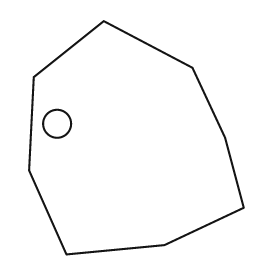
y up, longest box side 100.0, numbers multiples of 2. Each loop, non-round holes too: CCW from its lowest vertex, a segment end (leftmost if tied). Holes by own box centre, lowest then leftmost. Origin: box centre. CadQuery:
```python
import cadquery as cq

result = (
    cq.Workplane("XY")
    .moveTo(-30.0, -50.0)
    .lineTo(12.0, -46.0)
    .lineTo(46.0, -30.0)
    .lineTo(38.0, 0.0)
    .lineTo(24.0, 30.0)
    .lineTo(-14.0, 50.0)
    .lineTo(-44.0, 26.0)
    .lineTo(-46.0, -14.0)
    .close()
    .moveTo(-34.0, 6.0)
    .circle(6.0)
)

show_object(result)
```